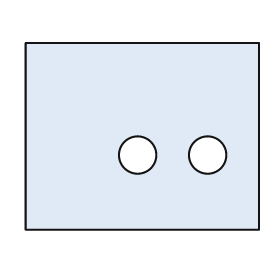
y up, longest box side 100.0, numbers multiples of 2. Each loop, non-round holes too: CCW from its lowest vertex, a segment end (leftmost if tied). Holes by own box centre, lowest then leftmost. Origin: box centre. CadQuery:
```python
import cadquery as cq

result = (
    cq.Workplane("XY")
    .moveTo(-50.0, -40.0)
    .lineTo(50.0, -40.0)
    .lineTo(50.0, 40.0)
    .lineTo(-50.0, 40.0)
    .close()
    .moveTo(-2.0, -8.0)
    .circle(8.0)
    .moveTo(28.0, -8.0)
    .circle(8.0)
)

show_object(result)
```